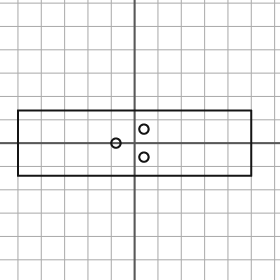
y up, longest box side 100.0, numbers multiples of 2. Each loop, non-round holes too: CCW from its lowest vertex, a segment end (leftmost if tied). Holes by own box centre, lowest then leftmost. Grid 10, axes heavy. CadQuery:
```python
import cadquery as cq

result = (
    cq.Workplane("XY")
    .moveTo(-50.0, -14.0)
    .lineTo(50.0, -14.0)
    .lineTo(50.0, 14.0)
    .lineTo(-50.0, 14.0)
    .close()
    .moveTo(4.0, -6.0)
    .circle(2.0)
    .moveTo(-8.0, 0.0)
    .circle(2.0)
    .moveTo(4.0, 6.0)
    .circle(2.0)
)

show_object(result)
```